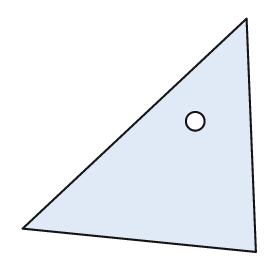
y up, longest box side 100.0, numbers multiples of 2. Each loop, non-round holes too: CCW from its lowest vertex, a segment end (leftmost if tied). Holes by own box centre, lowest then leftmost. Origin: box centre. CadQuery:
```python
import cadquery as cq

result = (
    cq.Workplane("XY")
    .moveTo(50.0, -50.0)
    .lineTo(46.0, 50.0)
    .lineTo(-50.0, -40.0)
    .close()
    .moveTo(24.0, 6.0)
    .circle(4.0)
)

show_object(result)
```